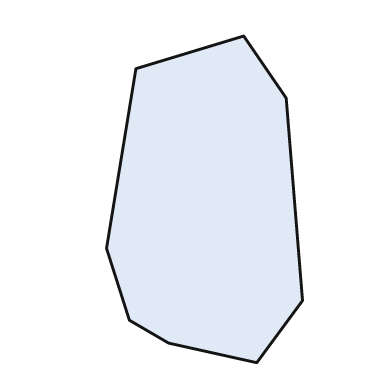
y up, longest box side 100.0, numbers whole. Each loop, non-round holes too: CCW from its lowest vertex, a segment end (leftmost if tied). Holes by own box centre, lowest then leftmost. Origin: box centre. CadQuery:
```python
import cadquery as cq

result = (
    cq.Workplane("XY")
    .moveTo(16.0, -50.0)
    .lineTo(30.0, -31.0)
    .lineTo(25.0, 31.0)
    .lineTo(12.0, 50.0)
    .lineTo(-21.0, 40.0)
    .lineTo(-30.0, -15.0)
    .lineTo(-23.0, -37.0)
    .lineTo(-11.0, -44.0)
    .close()
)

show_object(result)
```